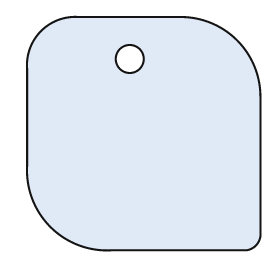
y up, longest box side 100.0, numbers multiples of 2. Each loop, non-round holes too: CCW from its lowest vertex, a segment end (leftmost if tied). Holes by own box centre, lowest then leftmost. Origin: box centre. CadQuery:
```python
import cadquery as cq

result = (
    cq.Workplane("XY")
    .moveTo(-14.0, -50.0)
    .lineTo(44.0, -50.0)
    .threePointArc((48.0, -48.0), (50.0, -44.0))
    .lineTo(50.0, 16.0)
    .threePointArc((40.0, 40.0), (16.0, 50.0))
    .lineTo(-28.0, 50.0)
    .threePointArc((-44.0, 44.0), (-50.0, 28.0))
    .lineTo(-50.0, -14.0)
    .threePointArc((-40.0, -40.0), (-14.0, -50.0))
    .close()
    .moveTo(-6.0, 32.0)
    .circle(6.0)
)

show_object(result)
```